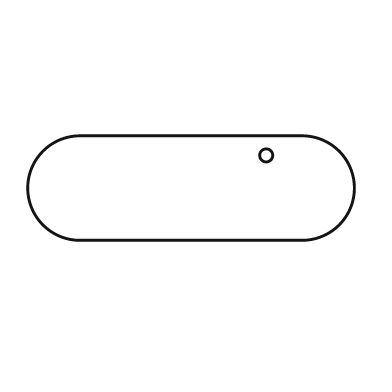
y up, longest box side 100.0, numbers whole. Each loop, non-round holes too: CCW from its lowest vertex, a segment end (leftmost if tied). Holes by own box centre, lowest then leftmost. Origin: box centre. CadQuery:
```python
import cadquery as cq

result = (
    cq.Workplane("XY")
    .moveTo(-34.0, -16.0)
    .lineTo(34.0, -16.0)
    .threePointArc((50.0, 0.0), (34.0, 16.0))
    .lineTo(-34.0, 16.0)
    .threePointArc((-50.0, 0.0), (-34.0, -16.0))
    .close()
    .moveTo(23.0, 10.0)
    .circle(2.0)
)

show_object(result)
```